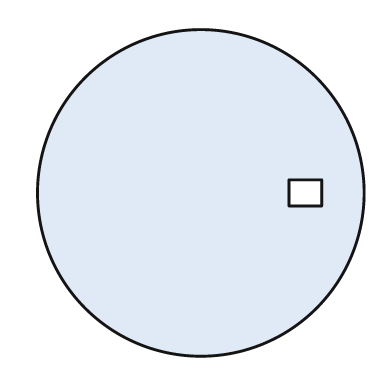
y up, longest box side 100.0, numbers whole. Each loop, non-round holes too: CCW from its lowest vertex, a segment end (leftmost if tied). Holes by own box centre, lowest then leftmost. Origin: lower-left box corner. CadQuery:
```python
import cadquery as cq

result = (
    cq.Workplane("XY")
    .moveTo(50.0, 50.0)
    .circle(50.0)
    .moveTo(77.0, 46.0)
    .lineTo(87.0, 46.0)
    .lineTo(87.0, 54.0)
    .lineTo(77.0, 54.0)
    .close()
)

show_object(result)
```